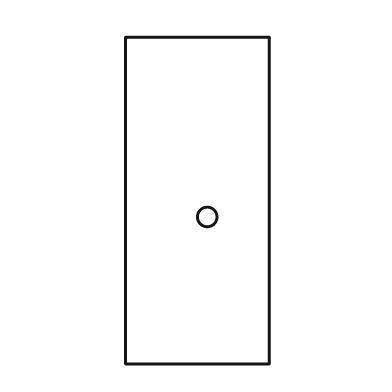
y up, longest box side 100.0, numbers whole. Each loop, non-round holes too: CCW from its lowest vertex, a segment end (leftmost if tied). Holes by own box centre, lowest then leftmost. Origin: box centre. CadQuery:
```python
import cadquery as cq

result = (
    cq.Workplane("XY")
    .moveTo(-22.0, -50.0)
    .lineTo(22.0, -50.0)
    .lineTo(22.0, 50.0)
    .lineTo(-22.0, 50.0)
    .close()
    .moveTo(3.0, -5.0)
    .circle(3.0)
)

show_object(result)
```